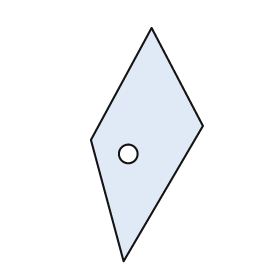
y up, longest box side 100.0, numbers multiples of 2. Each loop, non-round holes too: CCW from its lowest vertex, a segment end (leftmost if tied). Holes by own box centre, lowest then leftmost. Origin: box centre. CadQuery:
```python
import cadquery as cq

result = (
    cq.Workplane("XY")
    .moveTo(-10.0, -50.0)
    .lineTo(24.0, 8.0)
    .lineTo(2.0, 50.0)
    .lineTo(-24.0, 2.0)
    .close()
    .moveTo(-8.0, -4.0)
    .circle(4.0)
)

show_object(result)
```